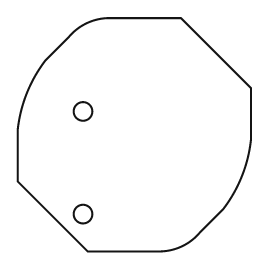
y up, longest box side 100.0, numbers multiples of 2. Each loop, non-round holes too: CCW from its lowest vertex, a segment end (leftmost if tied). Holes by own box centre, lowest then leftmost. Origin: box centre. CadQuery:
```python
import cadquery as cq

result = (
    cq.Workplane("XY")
    .moveTo(-20.0, -50.0)
    .lineTo(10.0, -50.0)
    .threePointArc((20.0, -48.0), (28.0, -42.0))
    .lineTo(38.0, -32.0)
    .threePointArc((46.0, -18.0), (50.0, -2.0))
    .lineTo(50.0, 20.0)
    .lineTo(20.0, 50.0)
    .lineTo(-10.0, 50.0)
    .threePointArc((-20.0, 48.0), (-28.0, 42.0))
    .lineTo(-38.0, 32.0)
    .threePointArc((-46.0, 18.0), (-50.0, 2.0))
    .lineTo(-50.0, -20.0)
    .close()
    .moveTo(-22.0, -34.0)
    .circle(4.0)
    .moveTo(-22.0, 10.0)
    .circle(4.0)
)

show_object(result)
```